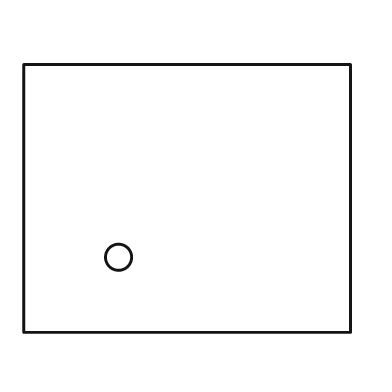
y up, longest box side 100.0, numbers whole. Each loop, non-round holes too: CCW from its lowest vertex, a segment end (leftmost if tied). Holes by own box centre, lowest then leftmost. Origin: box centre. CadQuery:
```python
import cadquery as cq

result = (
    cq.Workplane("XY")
    .moveTo(-50.0, -41.0)
    .lineTo(50.0, -41.0)
    .lineTo(50.0, 41.0)
    .lineTo(-50.0, 41.0)
    .close()
    .moveTo(-21.0, -18.0)
    .circle(4.0)
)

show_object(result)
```